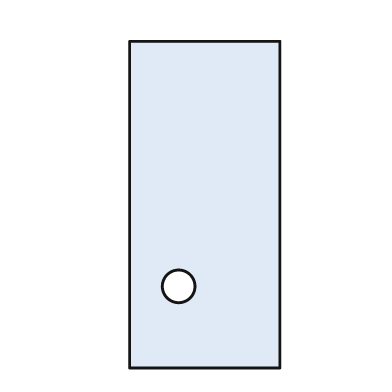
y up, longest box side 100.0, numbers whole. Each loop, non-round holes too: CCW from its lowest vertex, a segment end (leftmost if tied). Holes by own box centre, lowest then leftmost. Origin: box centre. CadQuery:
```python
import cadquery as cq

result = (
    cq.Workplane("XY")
    .moveTo(-23.0, -50.0)
    .lineTo(23.0, -50.0)
    .lineTo(23.0, 50.0)
    .lineTo(-23.0, 50.0)
    .close()
    .moveTo(-8.0, -25.0)
    .circle(5.0)
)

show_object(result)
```